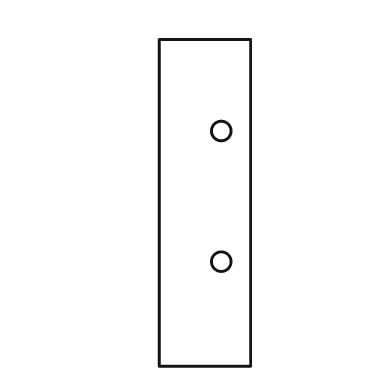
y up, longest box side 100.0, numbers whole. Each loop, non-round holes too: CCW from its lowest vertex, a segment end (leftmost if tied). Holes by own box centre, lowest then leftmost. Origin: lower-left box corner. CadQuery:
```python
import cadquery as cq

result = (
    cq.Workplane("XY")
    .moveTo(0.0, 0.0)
    .lineTo(28.0, 0.0)
    .lineTo(28.0, 100.0)
    .lineTo(0.0, 100.0)
    .close()
    .moveTo(19.0, 32.0)
    .circle(3.0)
    .moveTo(19.0, 72.0)
    .circle(3.0)
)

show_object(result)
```